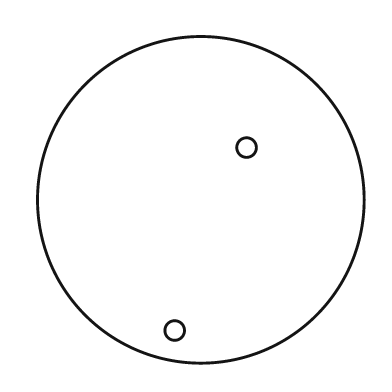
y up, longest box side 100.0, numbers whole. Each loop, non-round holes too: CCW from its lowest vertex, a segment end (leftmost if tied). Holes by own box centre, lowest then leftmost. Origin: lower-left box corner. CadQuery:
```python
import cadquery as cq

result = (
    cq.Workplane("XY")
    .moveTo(50.0, 50.0)
    .circle(50.0)
    .moveTo(42.0, 10.0)
    .circle(3.0)
    .moveTo(64.0, 66.0)
    .circle(3.0)
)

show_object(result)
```